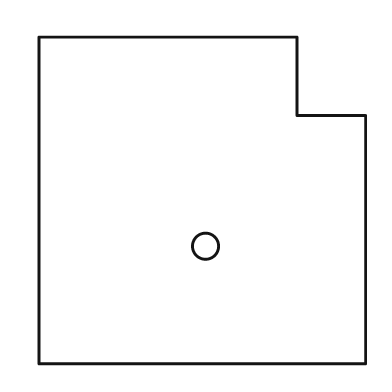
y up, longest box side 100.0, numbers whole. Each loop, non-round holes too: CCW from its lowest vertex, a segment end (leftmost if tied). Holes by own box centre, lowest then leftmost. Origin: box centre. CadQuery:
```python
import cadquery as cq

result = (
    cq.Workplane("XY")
    .moveTo(-50.0, -50.0)
    .lineTo(50.0, -50.0)
    .lineTo(50.0, 26.0)
    .lineTo(29.0, 26.0)
    .lineTo(29.0, 50.0)
    .lineTo(-50.0, 50.0)
    .close()
    .moveTo(1.0, -14.0)
    .circle(4.0)
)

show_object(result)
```